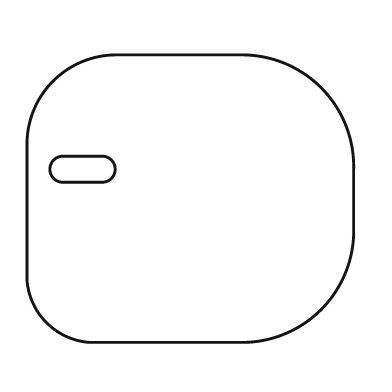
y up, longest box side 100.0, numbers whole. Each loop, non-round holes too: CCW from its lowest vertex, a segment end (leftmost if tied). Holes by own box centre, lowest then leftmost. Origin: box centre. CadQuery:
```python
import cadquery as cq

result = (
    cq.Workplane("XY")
    .moveTo(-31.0, -44.0)
    .lineTo(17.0, -44.0)
    .threePointArc((40.0, -34.0), (50.0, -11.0))
    .lineTo(50.0, 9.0)
    .threePointArc((40.0, 34.0), (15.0, 44.0))
    .lineTo(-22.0, 44.0)
    .threePointArc((-42.0, 36.0), (-50.0, 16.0))
    .lineTo(-50.0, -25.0)
    .threePointArc((-44.0, -38.0), (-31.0, -44.0))
    .close()
    .moveTo(-39.0, 5.0)
    .lineTo(-27.0, 5.0)
    .threePointArc((-23.0, 9.0), (-27.0, 13.0))
    .lineTo(-39.0, 13.0)
    .threePointArc((-43.0, 9.0), (-39.0, 5.0))
    .close()
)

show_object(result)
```